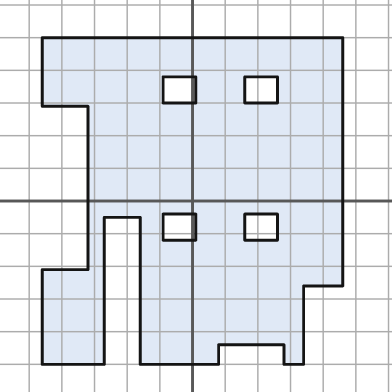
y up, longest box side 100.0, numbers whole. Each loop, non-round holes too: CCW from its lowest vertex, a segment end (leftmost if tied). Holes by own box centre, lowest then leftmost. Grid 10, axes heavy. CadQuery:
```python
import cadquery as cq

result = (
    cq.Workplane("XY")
    .moveTo(-46.0, -50.0)
    .lineTo(-27.0, -50.0)
    .lineTo(-27.0, -5.0)
    .lineTo(-16.0, -5.0)
    .lineTo(-16.0, -50.0)
    .lineTo(8.0, -50.0)
    .lineTo(8.0, -44.0)
    .lineTo(28.0, -44.0)
    .lineTo(28.0, -50.0)
    .lineTo(34.0, -50.0)
    .lineTo(34.0, -26.0)
    .lineTo(46.0, -26.0)
    .lineTo(46.0, 50.0)
    .lineTo(-46.0, 50.0)
    .lineTo(-46.0, 29.0)
    .lineTo(-32.0, 29.0)
    .lineTo(-32.0, -21.0)
    .lineTo(-46.0, -21.0)
    .close()
    .moveTo(-9.0, -12.0)
    .lineTo(1.0, -12.0)
    .lineTo(1.0, -4.0)
    .lineTo(-9.0, -4.0)
    .close()
    .moveTo(16.0, -12.0)
    .lineTo(26.0, -12.0)
    .lineTo(26.0, -4.0)
    .lineTo(16.0, -4.0)
    .close()
    .moveTo(-9.0, 30.0)
    .lineTo(1.0, 30.0)
    .lineTo(1.0, 38.0)
    .lineTo(-9.0, 38.0)
    .close()
    .moveTo(16.0, 30.0)
    .lineTo(26.0, 30.0)
    .lineTo(26.0, 38.0)
    .lineTo(16.0, 38.0)
    .close()
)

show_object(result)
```